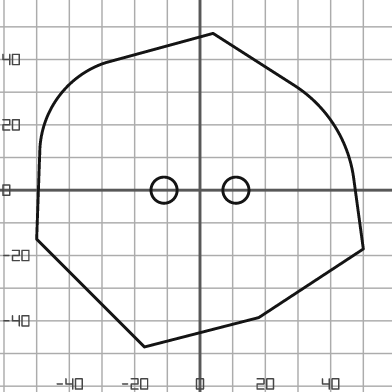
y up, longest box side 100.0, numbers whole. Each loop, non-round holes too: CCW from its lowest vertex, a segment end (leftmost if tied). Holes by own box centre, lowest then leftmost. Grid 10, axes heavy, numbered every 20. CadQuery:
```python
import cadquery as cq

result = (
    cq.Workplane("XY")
    .moveTo(-17.0, -48.0)
    .lineTo(18.0, -39.0)
    .lineTo(50.0, -18.0)
    .lineTo(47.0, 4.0)
    .threePointArc((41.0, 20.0), (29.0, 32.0))
    .lineTo(4.0, 48.0)
    .lineTo(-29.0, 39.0)
    .threePointArc((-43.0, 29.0), (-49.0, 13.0))
    .lineTo(-50.0, -15.0)
    .close()
    .moveTo(-11.0, 0.0)
    .circle(4.0)
    .moveTo(11.0, 0.0)
    .circle(4.0)
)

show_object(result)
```